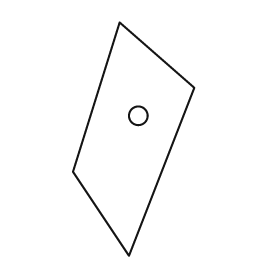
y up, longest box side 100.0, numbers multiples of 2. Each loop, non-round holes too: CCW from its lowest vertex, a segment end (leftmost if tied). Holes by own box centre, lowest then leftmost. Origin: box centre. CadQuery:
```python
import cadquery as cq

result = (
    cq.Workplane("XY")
    .moveTo(-2.0, -50.0)
    .lineTo(26.0, 22.0)
    .lineTo(-6.0, 50.0)
    .lineTo(-26.0, -14.0)
    .close()
    .moveTo(2.0, 10.0)
    .circle(4.0)
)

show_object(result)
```